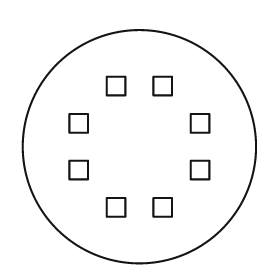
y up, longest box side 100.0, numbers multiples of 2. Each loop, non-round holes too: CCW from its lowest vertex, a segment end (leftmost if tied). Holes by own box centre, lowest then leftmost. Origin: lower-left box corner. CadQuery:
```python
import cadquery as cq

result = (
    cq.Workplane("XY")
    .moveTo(50.0, 50.0)
    .circle(50.0)
    .moveTo(36.0, 20.0)
    .lineTo(44.0, 20.0)
    .lineTo(44.0, 28.0)
    .lineTo(36.0, 28.0)
    .close()
    .moveTo(56.0, 20.0)
    .lineTo(64.0, 20.0)
    .lineTo(64.0, 28.0)
    .lineTo(56.0, 28.0)
    .close()
    .moveTo(20.0, 36.0)
    .lineTo(28.0, 36.0)
    .lineTo(28.0, 44.0)
    .lineTo(20.0, 44.0)
    .close()
    .moveTo(72.0, 36.0)
    .lineTo(80.0, 36.0)
    .lineTo(80.0, 44.0)
    .lineTo(72.0, 44.0)
    .close()
    .moveTo(20.0, 56.0)
    .lineTo(28.0, 56.0)
    .lineTo(28.0, 64.0)
    .lineTo(20.0, 64.0)
    .close()
    .moveTo(72.0, 56.0)
    .lineTo(80.0, 56.0)
    .lineTo(80.0, 64.0)
    .lineTo(72.0, 64.0)
    .close()
    .moveTo(36.0, 72.0)
    .lineTo(44.0, 72.0)
    .lineTo(44.0, 80.0)
    .lineTo(36.0, 80.0)
    .close()
    .moveTo(56.0, 72.0)
    .lineTo(64.0, 72.0)
    .lineTo(64.0, 80.0)
    .lineTo(56.0, 80.0)
    .close()
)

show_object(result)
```